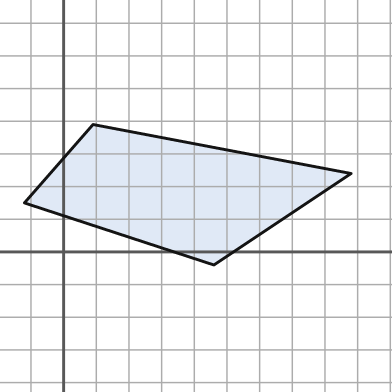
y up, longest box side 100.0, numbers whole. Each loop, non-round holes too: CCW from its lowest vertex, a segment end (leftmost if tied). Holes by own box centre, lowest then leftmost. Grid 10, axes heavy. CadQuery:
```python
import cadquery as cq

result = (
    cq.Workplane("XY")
    .moveTo(46.0, -4.0)
    .lineTo(88.0, 24.0)
    .lineTo(9.0, 39.0)
    .lineTo(-12.0, 15.0)
    .close()
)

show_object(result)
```